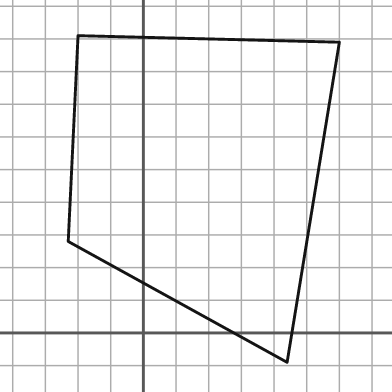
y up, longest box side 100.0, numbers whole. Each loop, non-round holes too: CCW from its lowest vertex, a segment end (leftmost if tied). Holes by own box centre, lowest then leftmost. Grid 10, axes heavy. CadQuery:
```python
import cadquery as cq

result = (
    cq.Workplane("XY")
    .moveTo(44.0, -9.0)
    .lineTo(60.0, 89.0)
    .lineTo(-20.0, 91.0)
    .lineTo(-23.0, 28.0)
    .close()
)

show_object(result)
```